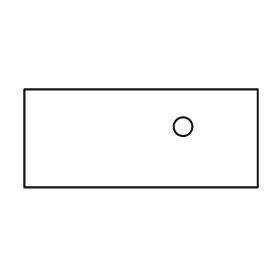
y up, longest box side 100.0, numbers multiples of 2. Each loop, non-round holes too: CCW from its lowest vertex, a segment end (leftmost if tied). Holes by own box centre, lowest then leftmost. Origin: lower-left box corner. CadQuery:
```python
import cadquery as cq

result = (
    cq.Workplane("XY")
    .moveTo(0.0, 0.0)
    .lineTo(100.0, 0.0)
    .lineTo(100.0, 42.0)
    .lineTo(0.0, 42.0)
    .close()
    .moveTo(68.0, 26.0)
    .circle(4.0)
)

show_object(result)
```